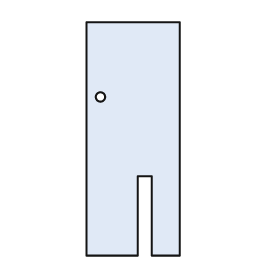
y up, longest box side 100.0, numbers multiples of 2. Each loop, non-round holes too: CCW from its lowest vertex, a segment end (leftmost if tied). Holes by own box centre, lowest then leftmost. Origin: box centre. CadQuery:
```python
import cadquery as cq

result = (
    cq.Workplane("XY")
    .moveTo(-20.0, -50.0)
    .lineTo(2.0, -50.0)
    .lineTo(2.0, -16.0)
    .lineTo(8.0, -16.0)
    .lineTo(8.0, -50.0)
    .lineTo(20.0, -50.0)
    .lineTo(20.0, 50.0)
    .lineTo(-20.0, 50.0)
    .close()
    .moveTo(-14.0, 18.0)
    .circle(2.0)
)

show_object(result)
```